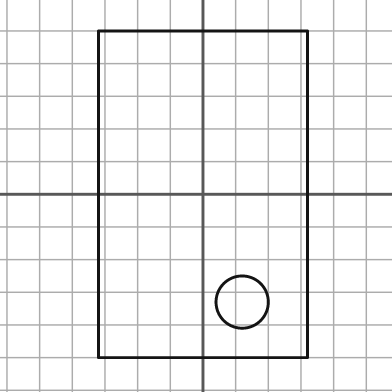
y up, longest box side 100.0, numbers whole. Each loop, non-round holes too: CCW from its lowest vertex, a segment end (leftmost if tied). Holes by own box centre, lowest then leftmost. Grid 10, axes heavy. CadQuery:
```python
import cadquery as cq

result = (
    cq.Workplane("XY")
    .moveTo(-32.0, -50.0)
    .lineTo(32.0, -50.0)
    .lineTo(32.0, 50.0)
    .lineTo(-32.0, 50.0)
    .close()
    .moveTo(12.0, -33.0)
    .circle(8.0)
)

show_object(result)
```